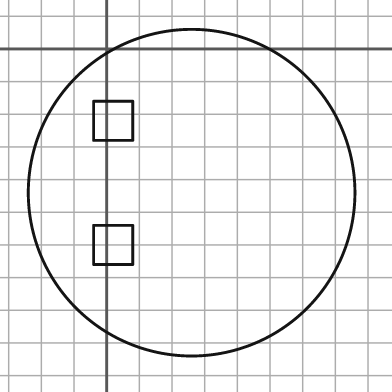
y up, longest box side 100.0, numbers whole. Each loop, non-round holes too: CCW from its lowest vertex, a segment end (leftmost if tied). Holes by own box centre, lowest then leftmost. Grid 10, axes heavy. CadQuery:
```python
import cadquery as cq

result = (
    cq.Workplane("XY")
    .moveTo(26.0, -44.0)
    .circle(50.0)
    .moveTo(-4.0, -66.0)
    .lineTo(8.0, -66.0)
    .lineTo(8.0, -54.0)
    .lineTo(-4.0, -54.0)
    .close()
    .moveTo(-4.0, -28.0)
    .lineTo(8.0, -28.0)
    .lineTo(8.0, -16.0)
    .lineTo(-4.0, -16.0)
    .close()
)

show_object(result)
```